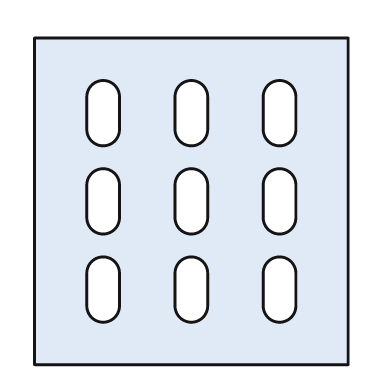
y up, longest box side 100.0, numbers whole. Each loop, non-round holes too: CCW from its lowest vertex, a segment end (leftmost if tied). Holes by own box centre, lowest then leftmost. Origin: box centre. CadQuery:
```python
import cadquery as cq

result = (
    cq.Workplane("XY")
    .moveTo(-48.0, -50.0)
    .lineTo(48.0, -50.0)
    .lineTo(48.0, 50.0)
    .lineTo(-48.0, 50.0)
    .close()
    .moveTo(-32.0, -32.0)
    .threePointArc((-27.0, -37.0), (-22.0, -32.0))
    .lineTo(-22.0, -22.0)
    .threePointArc((-27.0, -17.0), (-32.0, -22.0))
    .close()
    .moveTo(-5.0, -32.0)
    .threePointArc((0.0, -37.0), (5.0, -32.0))
    .lineTo(5.0, -22.0)
    .threePointArc((0.0, -17.0), (-5.0, -22.0))
    .close()
    .moveTo(22.0, -32.0)
    .threePointArc((27.0, -37.0), (32.0, -32.0))
    .lineTo(32.0, -22.0)
    .threePointArc((27.0, -17.0), (22.0, -22.0))
    .close()
    .moveTo(-32.0, -5.0)
    .threePointArc((-27.0, -10.0), (-22.0, -5.0))
    .lineTo(-22.0, 5.0)
    .threePointArc((-27.0, 10.0), (-32.0, 5.0))
    .close()
    .moveTo(-5.0, -5.0)
    .threePointArc((0.0, -10.0), (5.0, -5.0))
    .lineTo(5.0, 5.0)
    .threePointArc((0.0, 10.0), (-5.0, 5.0))
    .close()
    .moveTo(22.0, -5.0)
    .threePointArc((27.0, -10.0), (32.0, -5.0))
    .lineTo(32.0, 5.0)
    .threePointArc((27.0, 10.0), (22.0, 5.0))
    .close()
    .moveTo(-32.0, 22.0)
    .threePointArc((-27.0, 17.0), (-22.0, 22.0))
    .lineTo(-22.0, 32.0)
    .threePointArc((-27.0, 37.0), (-32.0, 32.0))
    .close()
    .moveTo(-5.0, 22.0)
    .threePointArc((0.0, 17.0), (5.0, 22.0))
    .lineTo(5.0, 32.0)
    .threePointArc((0.0, 37.0), (-5.0, 32.0))
    .close()
    .moveTo(22.0, 22.0)
    .threePointArc((27.0, 17.0), (32.0, 22.0))
    .lineTo(32.0, 32.0)
    .threePointArc((27.0, 37.0), (22.0, 32.0))
    .close()
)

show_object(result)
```